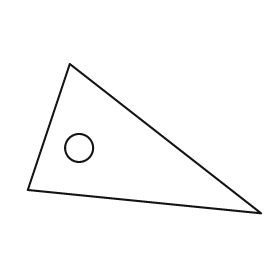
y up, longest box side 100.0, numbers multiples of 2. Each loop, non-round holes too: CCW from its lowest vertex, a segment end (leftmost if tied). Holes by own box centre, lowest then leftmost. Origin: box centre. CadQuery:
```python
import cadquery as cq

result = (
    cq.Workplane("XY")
    .moveTo(50.0, -32.0)
    .lineTo(-32.0, 32.0)
    .lineTo(-50.0, -22.0)
    .close()
    .moveTo(-28.0, -4.0)
    .circle(6.0)
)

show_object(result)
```